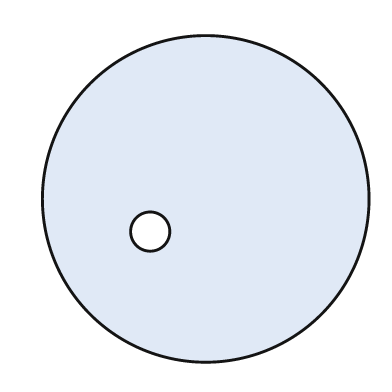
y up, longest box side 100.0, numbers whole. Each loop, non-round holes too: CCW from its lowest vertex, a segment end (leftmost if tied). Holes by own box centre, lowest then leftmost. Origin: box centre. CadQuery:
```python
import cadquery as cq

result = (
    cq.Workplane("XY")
    .moveTo(0.0, 0.0)
    .circle(50.0)
    .moveTo(-17.0, -10.0)
    .circle(6.0)
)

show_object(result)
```